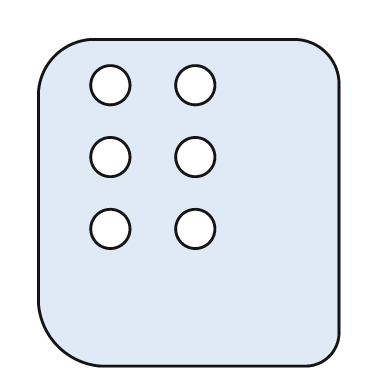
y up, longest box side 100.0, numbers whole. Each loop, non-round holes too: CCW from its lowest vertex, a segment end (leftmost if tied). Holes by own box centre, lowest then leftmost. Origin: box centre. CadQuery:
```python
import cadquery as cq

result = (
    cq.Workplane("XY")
    .moveTo(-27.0, -50.0)
    .lineTo(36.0, -50.0)
    .threePointArc((43.0, -47.0), (46.0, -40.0))
    .lineTo(46.0, 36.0)
    .threePointArc((42.0, 46.0), (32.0, 50.0))
    .lineTo(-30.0, 50.0)
    .threePointArc((-41.0, 45.0), (-46.0, 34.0))
    .lineTo(-46.0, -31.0)
    .threePointArc((-40.0, -44.0), (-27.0, -50.0))
    .close()
    .moveTo(-24.0, -8.0)
    .circle(6.0)
    .moveTo(2.0, -8.0)
    .circle(6.0)
    .moveTo(-24.0, 14.0)
    .circle(6.0)
    .moveTo(2.0, 14.0)
    .circle(6.0)
    .moveTo(-24.0, 36.0)
    .circle(6.0)
    .moveTo(2.0, 36.0)
    .circle(6.0)
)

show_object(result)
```